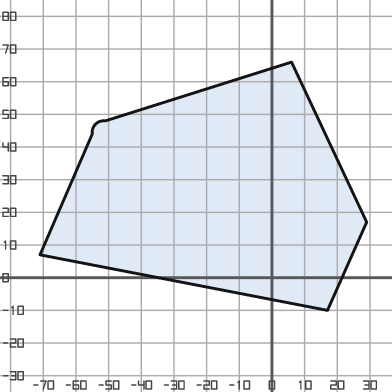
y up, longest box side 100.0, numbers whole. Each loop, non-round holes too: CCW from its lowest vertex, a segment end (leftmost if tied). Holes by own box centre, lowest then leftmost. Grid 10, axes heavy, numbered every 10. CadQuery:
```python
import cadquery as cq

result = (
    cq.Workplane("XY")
    .moveTo(17.0, -10.0)
    .lineTo(29.0, 17.0)
    .lineTo(6.0, 66.0)
    .lineTo(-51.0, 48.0)
    .threePointArc((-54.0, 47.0), (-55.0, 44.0))
    .lineTo(-71.0, 7.0)
    .close()
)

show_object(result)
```